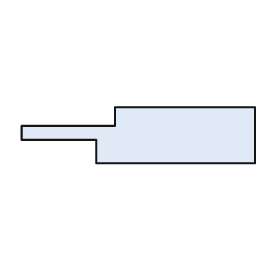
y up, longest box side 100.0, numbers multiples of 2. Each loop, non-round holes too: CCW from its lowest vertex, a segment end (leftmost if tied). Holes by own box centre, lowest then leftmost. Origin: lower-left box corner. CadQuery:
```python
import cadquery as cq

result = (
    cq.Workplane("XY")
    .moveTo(32.0, 0.0)
    .lineTo(100.0, 0.0)
    .lineTo(100.0, 24.0)
    .lineTo(40.0, 24.0)
    .lineTo(40.0, 16.0)
    .lineTo(0.0, 16.0)
    .lineTo(0.0, 10.0)
    .lineTo(32.0, 10.0)
    .close()
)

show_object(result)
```